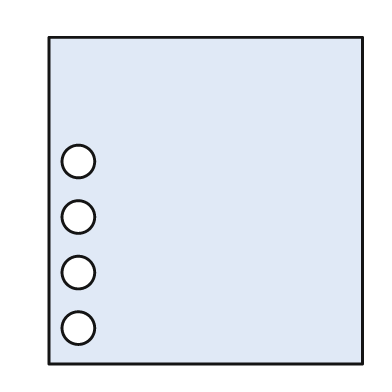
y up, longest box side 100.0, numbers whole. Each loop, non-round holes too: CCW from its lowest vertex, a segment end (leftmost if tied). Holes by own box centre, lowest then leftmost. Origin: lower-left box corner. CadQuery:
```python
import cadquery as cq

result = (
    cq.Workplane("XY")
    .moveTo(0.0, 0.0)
    .lineTo(96.0, 0.0)
    .lineTo(96.0, 100.0)
    .lineTo(0.0, 100.0)
    .close()
    .moveTo(9.0, 11.0)
    .circle(5.0)
    .moveTo(9.0, 28.0)
    .circle(5.0)
    .moveTo(9.0, 45.0)
    .circle(5.0)
    .moveTo(9.0, 62.0)
    .circle(5.0)
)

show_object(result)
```